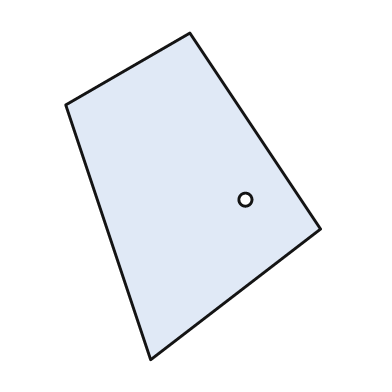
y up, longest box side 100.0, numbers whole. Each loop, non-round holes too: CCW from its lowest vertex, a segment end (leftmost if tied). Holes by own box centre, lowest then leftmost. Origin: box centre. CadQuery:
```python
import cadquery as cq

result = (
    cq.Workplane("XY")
    .moveTo(-13.0, -50.0)
    .lineTo(39.0, -10.0)
    .lineTo(-1.0, 50.0)
    .lineTo(-39.0, 28.0)
    .close()
    .moveTo(16.0, -1.0)
    .circle(2.0)
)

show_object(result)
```